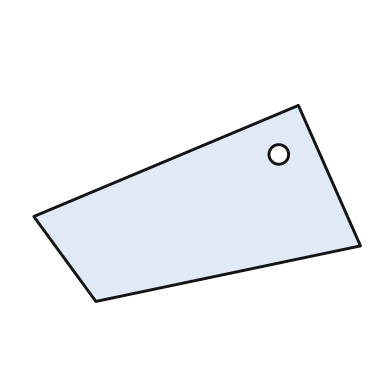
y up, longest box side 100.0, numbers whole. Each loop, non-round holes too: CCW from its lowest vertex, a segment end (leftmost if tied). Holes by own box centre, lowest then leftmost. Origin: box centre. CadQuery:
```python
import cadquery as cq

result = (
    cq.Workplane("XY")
    .moveTo(-31.0, -30.0)
    .lineTo(50.0, -13.0)
    .lineTo(31.0, 30.0)
    .lineTo(-50.0, -4.0)
    .close()
    .moveTo(25.0, 15.0)
    .circle(3.0)
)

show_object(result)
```